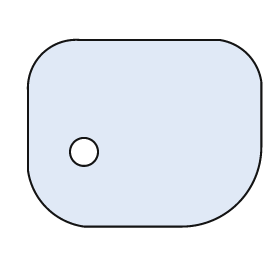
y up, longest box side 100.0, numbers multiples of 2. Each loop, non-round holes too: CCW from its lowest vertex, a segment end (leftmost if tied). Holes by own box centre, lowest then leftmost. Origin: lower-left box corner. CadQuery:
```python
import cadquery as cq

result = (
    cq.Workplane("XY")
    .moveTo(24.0, 0.0)
    .lineTo(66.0, 0.0)
    .threePointArc((90.0, 10.0), (100.0, 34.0))
    .lineTo(100.0, 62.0)
    .threePointArc((94.0, 74.0), (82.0, 80.0))
    .lineTo(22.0, 80.0)
    .threePointArc((6.0, 74.0), (0.0, 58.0))
    .lineTo(0.0, 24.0)
    .threePointArc((8.0, 8.0), (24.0, 0.0))
    .close()
    .moveTo(24.0, 32.0)
    .circle(6.0)
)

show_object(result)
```